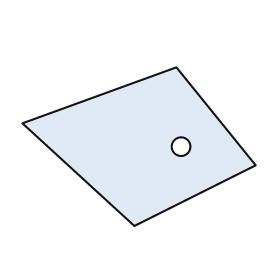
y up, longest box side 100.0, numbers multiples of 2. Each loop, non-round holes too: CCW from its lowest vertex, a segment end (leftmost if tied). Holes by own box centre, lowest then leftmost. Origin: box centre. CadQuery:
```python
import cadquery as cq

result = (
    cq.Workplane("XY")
    .moveTo(-2.0, -34.0)
    .lineTo(50.0, -8.0)
    .lineTo(16.0, 34.0)
    .lineTo(-50.0, 10.0)
    .close()
    .moveTo(18.0, 0.0)
    .circle(4.0)
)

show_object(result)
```